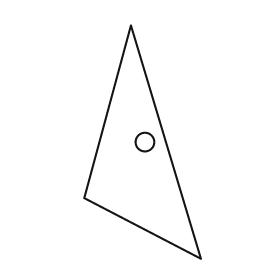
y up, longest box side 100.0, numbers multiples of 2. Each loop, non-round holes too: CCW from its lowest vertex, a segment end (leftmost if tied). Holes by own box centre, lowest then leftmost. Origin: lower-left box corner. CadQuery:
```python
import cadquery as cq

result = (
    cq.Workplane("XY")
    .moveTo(50.0, 0.0)
    .lineTo(20.0, 100.0)
    .lineTo(0.0, 26.0)
    .close()
    .moveTo(26.0, 50.0)
    .circle(4.0)
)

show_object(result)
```